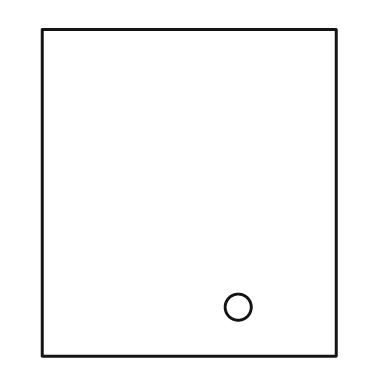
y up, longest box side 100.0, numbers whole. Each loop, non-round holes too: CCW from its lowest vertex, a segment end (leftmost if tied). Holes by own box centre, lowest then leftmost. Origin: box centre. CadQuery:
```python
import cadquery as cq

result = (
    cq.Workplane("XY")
    .moveTo(-45.0, -50.0)
    .lineTo(45.0, -50.0)
    .lineTo(45.0, 50.0)
    .lineTo(-45.0, 50.0)
    .close()
    .moveTo(15.0, -35.0)
    .circle(4.0)
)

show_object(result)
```